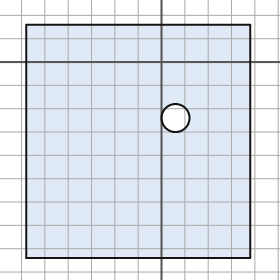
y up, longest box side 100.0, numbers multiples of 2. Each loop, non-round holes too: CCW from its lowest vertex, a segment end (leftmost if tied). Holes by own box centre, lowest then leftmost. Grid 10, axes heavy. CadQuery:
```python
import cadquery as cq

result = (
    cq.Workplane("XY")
    .moveTo(-58.0, -84.0)
    .lineTo(38.0, -84.0)
    .lineTo(38.0, 16.0)
    .lineTo(-58.0, 16.0)
    .close()
    .moveTo(6.0, -24.0)
    .circle(6.0)
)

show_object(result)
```